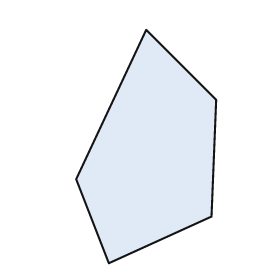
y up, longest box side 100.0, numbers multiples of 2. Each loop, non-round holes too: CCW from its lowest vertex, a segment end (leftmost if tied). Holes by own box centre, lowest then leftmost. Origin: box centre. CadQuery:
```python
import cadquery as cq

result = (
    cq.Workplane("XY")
    .moveTo(-16.0, -50.0)
    .lineTo(28.0, -30.0)
    .lineTo(30.0, 20.0)
    .lineTo(0.0, 50.0)
    .lineTo(-30.0, -14.0)
    .close()
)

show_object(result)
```